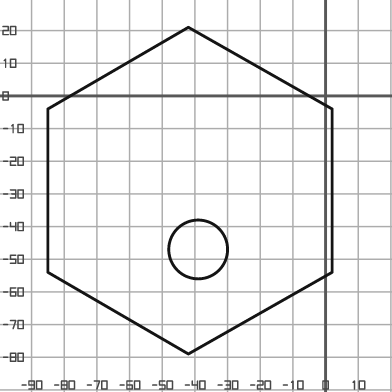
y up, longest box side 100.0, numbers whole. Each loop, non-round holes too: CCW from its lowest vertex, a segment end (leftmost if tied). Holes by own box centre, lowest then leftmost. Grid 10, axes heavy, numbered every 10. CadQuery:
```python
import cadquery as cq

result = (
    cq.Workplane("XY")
    .moveTo(-42.0, -79.0)
    .lineTo(2.0, -54.0)
    .lineTo(2.0, -4.0)
    .lineTo(-42.0, 21.0)
    .lineTo(-85.0, -4.0)
    .lineTo(-85.0, -54.0)
    .close()
    .moveTo(-39.0, -47.0)
    .circle(9.0)
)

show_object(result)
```